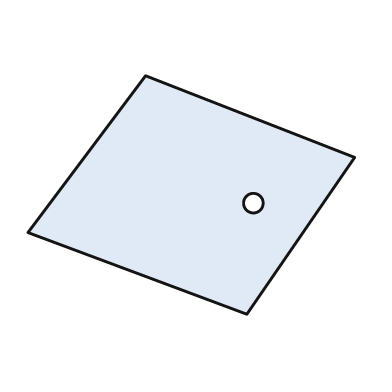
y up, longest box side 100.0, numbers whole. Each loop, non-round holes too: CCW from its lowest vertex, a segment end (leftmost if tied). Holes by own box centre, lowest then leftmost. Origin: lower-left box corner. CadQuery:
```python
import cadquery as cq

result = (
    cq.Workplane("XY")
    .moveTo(67.0, 0.0)
    .lineTo(100.0, 48.0)
    .lineTo(36.0, 73.0)
    .lineTo(0.0, 25.0)
    .close()
    .moveTo(69.0, 34.0)
    .circle(3.0)
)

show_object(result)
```